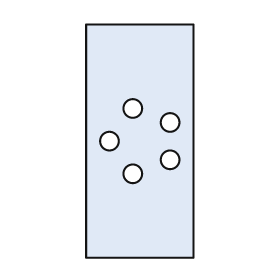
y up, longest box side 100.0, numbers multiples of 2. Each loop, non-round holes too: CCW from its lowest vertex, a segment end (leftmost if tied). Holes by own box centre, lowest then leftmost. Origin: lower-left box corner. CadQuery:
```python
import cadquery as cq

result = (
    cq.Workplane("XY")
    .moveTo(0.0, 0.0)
    .lineTo(46.0, 0.0)
    .lineTo(46.0, 100.0)
    .lineTo(0.0, 100.0)
    .close()
    .moveTo(20.0, 36.0)
    .circle(4.0)
    .moveTo(36.0, 42.0)
    .circle(4.0)
    .moveTo(10.0, 50.0)
    .circle(4.0)
    .moveTo(36.0, 58.0)
    .circle(4.0)
    .moveTo(20.0, 64.0)
    .circle(4.0)
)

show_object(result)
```